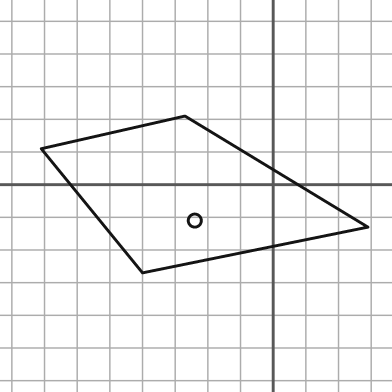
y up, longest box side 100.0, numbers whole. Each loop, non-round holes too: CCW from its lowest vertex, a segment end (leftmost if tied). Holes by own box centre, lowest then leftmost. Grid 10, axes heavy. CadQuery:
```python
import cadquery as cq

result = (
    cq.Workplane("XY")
    .moveTo(-40.0, -27.0)
    .lineTo(29.0, -13.0)
    .lineTo(-27.0, 21.0)
    .lineTo(-71.0, 11.0)
    .close()
    .moveTo(-24.0, -11.0)
    .circle(2.0)
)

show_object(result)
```